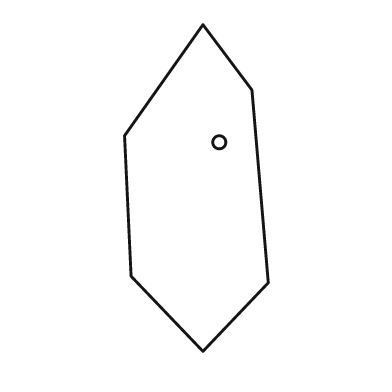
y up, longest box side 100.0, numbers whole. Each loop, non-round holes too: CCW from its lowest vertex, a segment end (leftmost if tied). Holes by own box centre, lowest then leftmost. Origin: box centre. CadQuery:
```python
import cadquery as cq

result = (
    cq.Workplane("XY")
    .moveTo(2.0, -50.0)
    .lineTo(22.0, -29.0)
    .lineTo(17.0, 30.0)
    .lineTo(2.0, 50.0)
    .lineTo(-22.0, 16.0)
    .lineTo(-20.0, -27.0)
    .close()
    .moveTo(7.0, 14.0)
    .circle(2.0)
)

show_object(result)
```